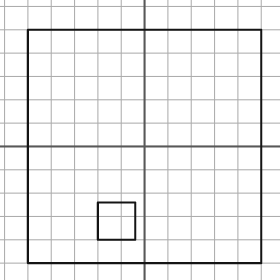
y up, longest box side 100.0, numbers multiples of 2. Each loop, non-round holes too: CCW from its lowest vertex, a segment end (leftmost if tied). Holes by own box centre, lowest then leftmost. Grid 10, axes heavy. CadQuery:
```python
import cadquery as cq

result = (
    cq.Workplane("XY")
    .moveTo(-50.0, -50.0)
    .lineTo(50.0, -50.0)
    .lineTo(50.0, 50.0)
    .lineTo(-50.0, 50.0)
    .close()
    .moveTo(-20.0, -40.0)
    .lineTo(-4.0, -40.0)
    .lineTo(-4.0, -24.0)
    .lineTo(-20.0, -24.0)
    .close()
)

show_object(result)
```